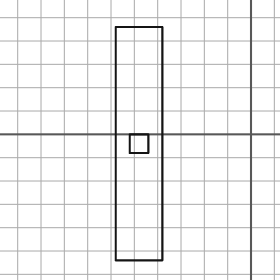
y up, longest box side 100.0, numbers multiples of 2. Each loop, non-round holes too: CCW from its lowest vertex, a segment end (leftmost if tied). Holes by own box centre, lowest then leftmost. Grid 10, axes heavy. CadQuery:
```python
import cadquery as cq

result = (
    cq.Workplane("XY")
    .moveTo(-58.0, -54.0)
    .lineTo(-38.0, -54.0)
    .lineTo(-38.0, 46.0)
    .lineTo(-58.0, 46.0)
    .close()
    .moveTo(-52.0, -8.0)
    .lineTo(-44.0, -8.0)
    .lineTo(-44.0, 0.0)
    .lineTo(-52.0, 0.0)
    .close()
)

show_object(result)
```